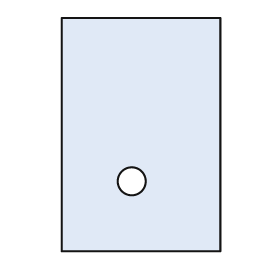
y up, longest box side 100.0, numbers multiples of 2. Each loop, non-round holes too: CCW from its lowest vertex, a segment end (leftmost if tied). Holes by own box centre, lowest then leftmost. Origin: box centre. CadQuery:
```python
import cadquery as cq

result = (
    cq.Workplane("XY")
    .moveTo(-34.0, -50.0)
    .lineTo(34.0, -50.0)
    .lineTo(34.0, 50.0)
    .lineTo(-34.0, 50.0)
    .close()
    .moveTo(-4.0, -20.0)
    .circle(6.0)
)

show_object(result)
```